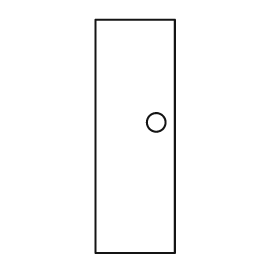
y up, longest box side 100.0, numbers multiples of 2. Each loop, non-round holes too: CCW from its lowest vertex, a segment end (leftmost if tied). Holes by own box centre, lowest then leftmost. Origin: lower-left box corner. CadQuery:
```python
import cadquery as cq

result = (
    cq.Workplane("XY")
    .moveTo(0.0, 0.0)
    .lineTo(34.0, 0.0)
    .lineTo(34.0, 100.0)
    .lineTo(0.0, 100.0)
    .close()
    .moveTo(26.0, 56.0)
    .circle(4.0)
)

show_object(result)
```